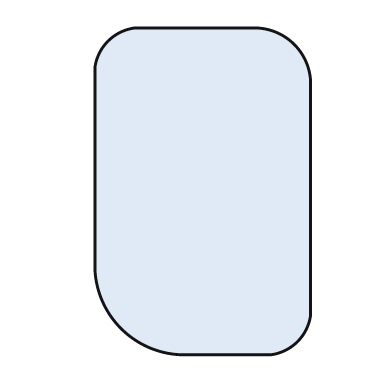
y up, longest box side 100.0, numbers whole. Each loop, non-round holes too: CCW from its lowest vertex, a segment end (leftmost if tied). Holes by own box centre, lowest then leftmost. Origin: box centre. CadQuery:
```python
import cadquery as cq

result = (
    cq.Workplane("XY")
    .moveTo(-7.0, -50.0)
    .lineTo(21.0, -50.0)
    .threePointArc((29.0, -46.0), (33.0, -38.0))
    .lineTo(33.0, 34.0)
    .threePointArc((28.0, 45.0), (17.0, 50.0))
    .lineTo(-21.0, 50.0)
    .threePointArc((-29.0, 46.0), (-33.0, 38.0))
    .lineTo(-33.0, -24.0)
    .threePointArc((-25.0, -42.0), (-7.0, -50.0))
    .close()
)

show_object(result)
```